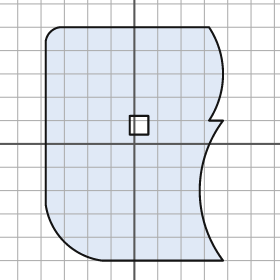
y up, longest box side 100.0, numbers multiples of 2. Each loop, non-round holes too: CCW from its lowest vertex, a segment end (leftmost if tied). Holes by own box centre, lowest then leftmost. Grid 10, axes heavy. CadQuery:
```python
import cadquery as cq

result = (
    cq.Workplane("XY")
    .moveTo(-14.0, -50.0)
    .lineTo(38.0, -50.0)
    .threePointArc((28.0, -20.0), (38.0, 10.0))
    .lineTo(32.0, 10.0)
    .threePointArc((38.0, 30.0), (32.0, 50.0))
    .lineTo(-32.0, 50.0)
    .threePointArc((-36.0, 48.0), (-38.0, 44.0))
    .lineTo(-38.0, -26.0)
    .threePointArc((-30.0, -42.0), (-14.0, -50.0))
    .close()
    .moveTo(-2.0, 4.0)
    .lineTo(6.0, 4.0)
    .lineTo(6.0, 12.0)
    .lineTo(-2.0, 12.0)
    .close()
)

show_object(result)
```